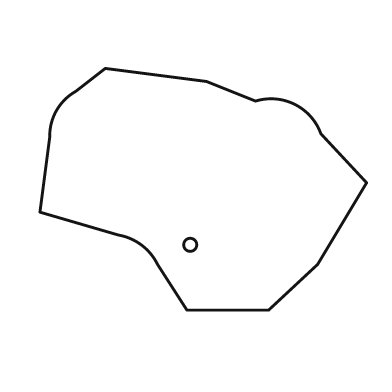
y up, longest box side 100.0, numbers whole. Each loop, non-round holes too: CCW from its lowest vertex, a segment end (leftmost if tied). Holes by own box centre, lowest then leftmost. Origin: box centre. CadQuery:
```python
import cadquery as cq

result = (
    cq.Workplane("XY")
    .moveTo(-5.0, -37.0)
    .lineTo(20.0, -37.0)
    .lineTo(35.0, -23.0)
    .lineTo(50.0, 2.0)
    .lineTo(36.0, 17.0)
    .threePointArc((28.0, 26.0), (16.0, 27.0))
    .lineTo(1.0, 33.0)
    .lineTo(-30.0, 37.0)
    .lineTo(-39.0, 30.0)
    .threePointArc((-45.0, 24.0), (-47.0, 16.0))
    .lineTo(-50.0, -7.0)
    .lineTo(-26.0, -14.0)
    .threePointArc((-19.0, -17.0), (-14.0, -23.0))
    .close()
    .moveTo(-4.0, -17.0)
    .circle(2.0)
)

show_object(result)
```